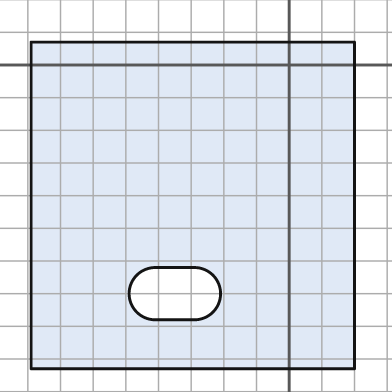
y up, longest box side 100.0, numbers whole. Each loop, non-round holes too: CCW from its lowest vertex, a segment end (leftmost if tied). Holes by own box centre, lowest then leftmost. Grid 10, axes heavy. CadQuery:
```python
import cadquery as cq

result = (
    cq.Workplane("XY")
    .moveTo(-79.0, -93.0)
    .lineTo(20.0, -93.0)
    .lineTo(20.0, 7.0)
    .lineTo(-79.0, 7.0)
    .close()
    .moveTo(-41.0, -78.0)
    .lineTo(-29.0, -78.0)
    .threePointArc((-21.0, -70.0), (-29.0, -62.0))
    .lineTo(-41.0, -62.0)
    .threePointArc((-49.0, -70.0), (-41.0, -78.0))
    .close()
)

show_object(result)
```